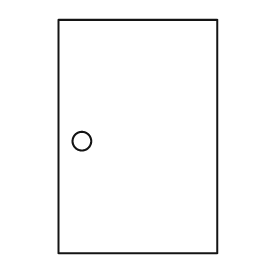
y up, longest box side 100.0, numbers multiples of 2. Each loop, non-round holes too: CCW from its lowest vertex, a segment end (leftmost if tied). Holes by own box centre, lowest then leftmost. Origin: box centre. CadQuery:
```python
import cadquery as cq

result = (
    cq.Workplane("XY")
    .moveTo(-34.0, -50.0)
    .lineTo(34.0, -50.0)
    .lineTo(34.0, 50.0)
    .lineTo(-34.0, 50.0)
    .close()
    .moveTo(-24.0, -2.0)
    .circle(4.0)
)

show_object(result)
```